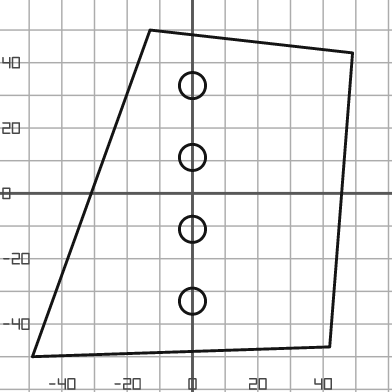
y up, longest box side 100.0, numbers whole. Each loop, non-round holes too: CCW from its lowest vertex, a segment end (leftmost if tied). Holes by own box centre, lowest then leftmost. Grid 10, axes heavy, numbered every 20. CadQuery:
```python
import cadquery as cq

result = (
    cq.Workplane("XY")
    .moveTo(-49.0, -50.0)
    .lineTo(42.0, -47.0)
    .lineTo(49.0, 43.0)
    .lineTo(-13.0, 50.0)
    .close()
    .moveTo(0.0, -33.0)
    .circle(4.0)
    .moveTo(0.0, -11.0)
    .circle(4.0)
    .moveTo(0.0, 11.0)
    .circle(4.0)
    .moveTo(0.0, 33.0)
    .circle(4.0)
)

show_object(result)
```